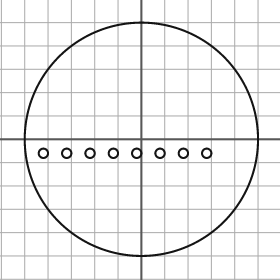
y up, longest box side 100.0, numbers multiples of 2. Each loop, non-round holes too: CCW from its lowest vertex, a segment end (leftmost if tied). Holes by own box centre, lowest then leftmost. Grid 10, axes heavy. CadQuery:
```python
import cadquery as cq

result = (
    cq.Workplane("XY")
    .moveTo(0.0, 0.0)
    .circle(50.0)
    .moveTo(-42.0, -6.0)
    .circle(2.0)
    .moveTo(-32.0, -6.0)
    .circle(2.0)
    .moveTo(-22.0, -6.0)
    .circle(2.0)
    .moveTo(-12.0, -6.0)
    .circle(2.0)
    .moveTo(-2.0, -6.0)
    .circle(2.0)
    .moveTo(8.0, -6.0)
    .circle(2.0)
    .moveTo(18.0, -6.0)
    .circle(2.0)
    .moveTo(28.0, -6.0)
    .circle(2.0)
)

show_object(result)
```